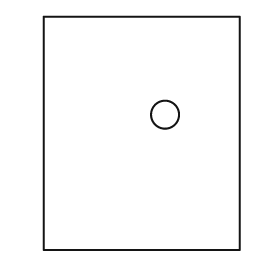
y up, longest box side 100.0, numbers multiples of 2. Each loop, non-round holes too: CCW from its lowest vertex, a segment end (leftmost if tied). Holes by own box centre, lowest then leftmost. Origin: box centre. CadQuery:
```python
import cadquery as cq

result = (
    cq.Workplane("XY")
    .moveTo(-42.0, -50.0)
    .lineTo(42.0, -50.0)
    .lineTo(42.0, 50.0)
    .lineTo(-42.0, 50.0)
    .close()
    .moveTo(10.0, 8.0)
    .circle(6.0)
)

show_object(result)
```